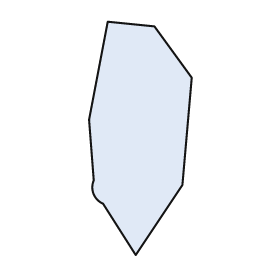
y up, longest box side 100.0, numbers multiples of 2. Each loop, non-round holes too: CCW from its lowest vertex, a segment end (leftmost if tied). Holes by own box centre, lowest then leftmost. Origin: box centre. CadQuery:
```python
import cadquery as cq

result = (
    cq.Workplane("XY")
    .moveTo(-2.0, -50.0)
    .lineTo(18.0, -20.0)
    .lineTo(22.0, 26.0)
    .lineTo(6.0, 48.0)
    .lineTo(-14.0, 50.0)
    .lineTo(-22.0, 8.0)
    .lineTo(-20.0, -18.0)
    .threePointArc((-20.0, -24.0), (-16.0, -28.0))
    .close()
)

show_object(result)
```